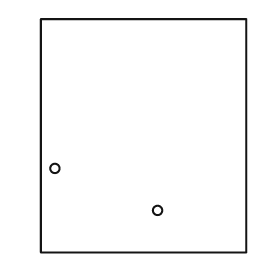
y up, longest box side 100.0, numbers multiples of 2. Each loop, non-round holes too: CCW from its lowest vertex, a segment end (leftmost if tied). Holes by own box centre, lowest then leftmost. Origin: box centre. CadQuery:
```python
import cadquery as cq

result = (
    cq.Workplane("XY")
    .moveTo(-44.0, -50.0)
    .lineTo(44.0, -50.0)
    .lineTo(44.0, 50.0)
    .lineTo(-44.0, 50.0)
    .close()
    .moveTo(6.0, -32.0)
    .circle(2.0)
    .moveTo(-38.0, -14.0)
    .circle(2.0)
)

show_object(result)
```